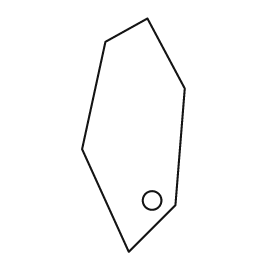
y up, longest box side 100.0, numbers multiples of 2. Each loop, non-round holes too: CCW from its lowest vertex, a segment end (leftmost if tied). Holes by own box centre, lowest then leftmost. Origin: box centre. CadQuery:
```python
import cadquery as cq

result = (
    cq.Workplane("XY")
    .moveTo(-2.0, -50.0)
    .lineTo(18.0, -30.0)
    .lineTo(22.0, 20.0)
    .lineTo(6.0, 50.0)
    .lineTo(-12.0, 40.0)
    .lineTo(-22.0, -6.0)
    .close()
    .moveTo(8.0, -28.0)
    .circle(4.0)
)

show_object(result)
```